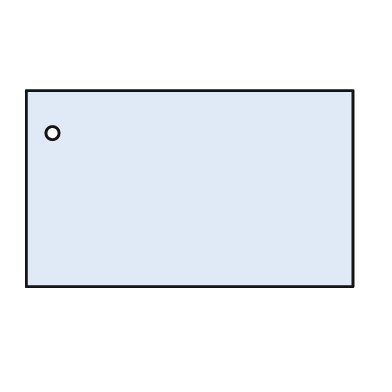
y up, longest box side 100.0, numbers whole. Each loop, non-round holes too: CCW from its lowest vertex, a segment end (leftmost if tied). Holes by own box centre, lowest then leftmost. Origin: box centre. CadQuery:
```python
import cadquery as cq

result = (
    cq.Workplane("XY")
    .moveTo(-50.0, -30.0)
    .lineTo(50.0, -30.0)
    .lineTo(50.0, 30.0)
    .lineTo(-50.0, 30.0)
    .close()
    .moveTo(-42.0, 17.0)
    .circle(2.0)
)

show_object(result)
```